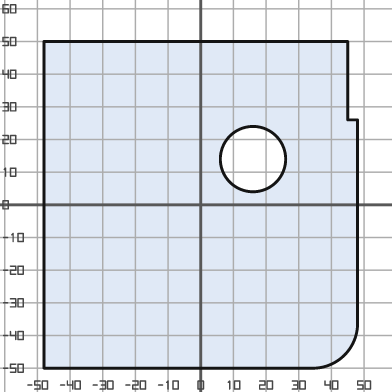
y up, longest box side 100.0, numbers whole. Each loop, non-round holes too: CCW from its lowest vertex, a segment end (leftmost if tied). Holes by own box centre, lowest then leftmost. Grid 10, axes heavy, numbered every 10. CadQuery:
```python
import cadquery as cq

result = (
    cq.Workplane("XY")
    .moveTo(-48.0, -50.0)
    .lineTo(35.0, -50.0)
    .threePointArc((44.0, -46.0), (48.0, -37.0))
    .lineTo(48.0, 26.0)
    .lineTo(45.0, 26.0)
    .lineTo(45.0, 50.0)
    .lineTo(-48.0, 50.0)
    .close()
    .moveTo(16.0, 14.0)
    .circle(10.0)
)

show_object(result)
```